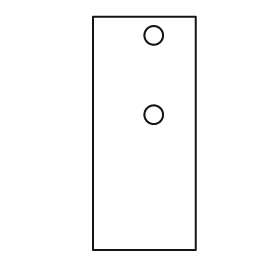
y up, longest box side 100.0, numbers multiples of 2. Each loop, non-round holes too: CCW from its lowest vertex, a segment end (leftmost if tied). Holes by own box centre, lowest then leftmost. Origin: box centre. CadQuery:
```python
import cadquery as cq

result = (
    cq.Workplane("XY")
    .moveTo(-22.0, -50.0)
    .lineTo(22.0, -50.0)
    .lineTo(22.0, 50.0)
    .lineTo(-22.0, 50.0)
    .close()
    .moveTo(4.0, 8.0)
    .circle(4.0)
    .moveTo(4.0, 42.0)
    .circle(4.0)
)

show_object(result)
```